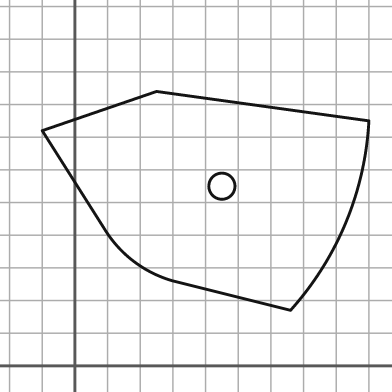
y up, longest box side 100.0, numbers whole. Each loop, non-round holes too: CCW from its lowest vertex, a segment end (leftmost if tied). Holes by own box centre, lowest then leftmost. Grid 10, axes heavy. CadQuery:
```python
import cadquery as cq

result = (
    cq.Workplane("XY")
    .moveTo(66.0, 17.0)
    .threePointArc((83.0, 44.0), (90.0, 75.0))
    .lineTo(25.0, 84.0)
    .lineTo(-10.0, 72.0)
    .lineTo(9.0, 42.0)
    .threePointArc((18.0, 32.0), (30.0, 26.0))
    .close()
    .moveTo(45.0, 55.0)
    .circle(4.0)
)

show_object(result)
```